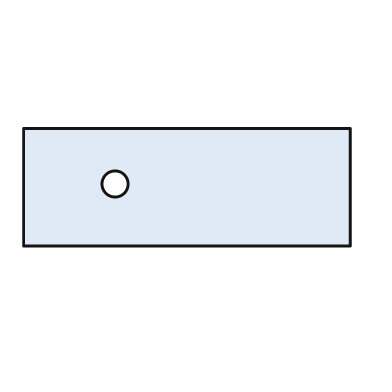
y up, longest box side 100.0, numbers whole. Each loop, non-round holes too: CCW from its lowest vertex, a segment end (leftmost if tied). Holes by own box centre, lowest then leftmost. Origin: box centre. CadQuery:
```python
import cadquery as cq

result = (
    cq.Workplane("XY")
    .moveTo(-50.0, -18.0)
    .lineTo(50.0, -18.0)
    .lineTo(50.0, 18.0)
    .lineTo(-50.0, 18.0)
    .close()
    .moveTo(-22.0, 1.0)
    .circle(4.0)
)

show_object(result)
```